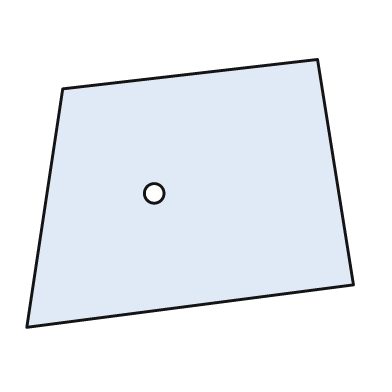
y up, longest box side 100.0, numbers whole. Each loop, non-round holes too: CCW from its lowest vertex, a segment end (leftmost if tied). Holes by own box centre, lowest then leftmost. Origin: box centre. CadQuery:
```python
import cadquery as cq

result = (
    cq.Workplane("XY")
    .moveTo(-50.0, -41.0)
    .lineTo(50.0, -28.0)
    .lineTo(39.0, 41.0)
    .lineTo(-39.0, 32.0)
    .close()
    .moveTo(-11.0, 0.0)
    .circle(3.0)
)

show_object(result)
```